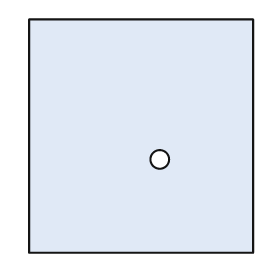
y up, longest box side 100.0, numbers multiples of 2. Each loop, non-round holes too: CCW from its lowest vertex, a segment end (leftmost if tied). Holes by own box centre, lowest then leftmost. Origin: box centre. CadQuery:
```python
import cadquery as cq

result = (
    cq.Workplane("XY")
    .moveTo(-48.0, -50.0)
    .lineTo(48.0, -50.0)
    .lineTo(48.0, 50.0)
    .lineTo(-48.0, 50.0)
    .close()
    .moveTo(8.0, -10.0)
    .circle(4.0)
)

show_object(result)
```